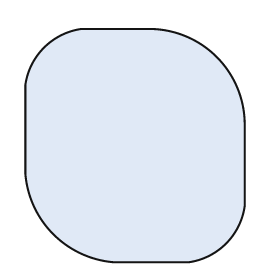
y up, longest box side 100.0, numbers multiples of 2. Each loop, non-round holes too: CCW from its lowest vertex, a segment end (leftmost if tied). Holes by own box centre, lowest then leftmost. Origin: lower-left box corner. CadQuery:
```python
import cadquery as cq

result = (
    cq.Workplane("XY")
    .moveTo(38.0, 0.0)
    .lineTo(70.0, 0.0)
    .threePointArc((86.0, 8.0), (94.0, 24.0))
    .lineTo(94.0, 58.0)
    .threePointArc((82.0, 88.0), (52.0, 100.0))
    .lineTo(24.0, 100.0)
    .threePointArc((8.0, 92.0), (0.0, 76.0))
    .lineTo(0.0, 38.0)
    .threePointArc((12.0, 12.0), (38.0, 0.0))
    .close()
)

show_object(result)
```